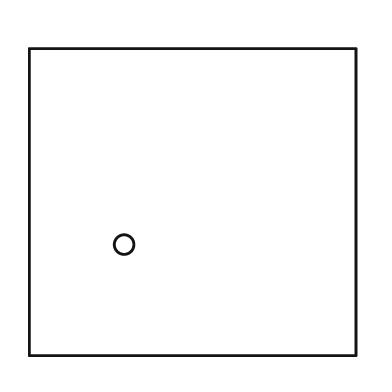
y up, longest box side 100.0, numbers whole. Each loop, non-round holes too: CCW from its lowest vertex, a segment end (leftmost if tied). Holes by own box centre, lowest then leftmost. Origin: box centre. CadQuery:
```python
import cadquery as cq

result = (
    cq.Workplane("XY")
    .moveTo(-50.0, -47.0)
    .lineTo(50.0, -47.0)
    .lineTo(50.0, 47.0)
    .lineTo(-50.0, 47.0)
    .close()
    .moveTo(-21.0, -13.0)
    .circle(3.0)
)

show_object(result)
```